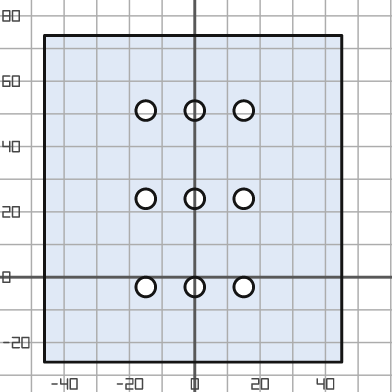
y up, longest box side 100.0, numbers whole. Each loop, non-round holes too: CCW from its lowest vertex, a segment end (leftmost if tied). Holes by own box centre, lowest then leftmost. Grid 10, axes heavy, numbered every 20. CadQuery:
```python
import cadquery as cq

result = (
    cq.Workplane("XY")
    .moveTo(-46.0, -26.0)
    .lineTo(45.0, -26.0)
    .lineTo(45.0, 74.0)
    .lineTo(-46.0, 74.0)
    .close()
    .moveTo(-15.0, -3.0)
    .circle(3.0)
    .moveTo(0.0, -3.0)
    .circle(3.0)
    .moveTo(15.0, -3.0)
    .circle(3.0)
    .moveTo(-15.0, 24.0)
    .circle(3.0)
    .moveTo(0.0, 24.0)
    .circle(3.0)
    .moveTo(15.0, 24.0)
    .circle(3.0)
    .moveTo(-15.0, 51.0)
    .circle(3.0)
    .moveTo(0.0, 51.0)
    .circle(3.0)
    .moveTo(15.0, 51.0)
    .circle(3.0)
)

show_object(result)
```